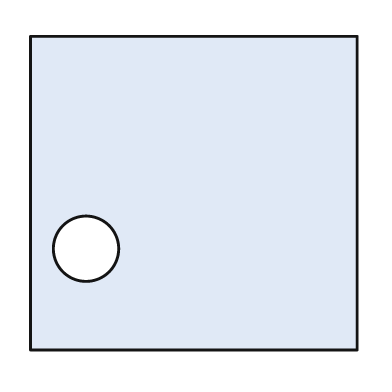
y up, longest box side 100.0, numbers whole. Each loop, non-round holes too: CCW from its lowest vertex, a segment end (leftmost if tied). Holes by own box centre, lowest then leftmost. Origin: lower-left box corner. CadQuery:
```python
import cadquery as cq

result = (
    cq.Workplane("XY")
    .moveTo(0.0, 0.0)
    .lineTo(100.0, 0.0)
    .lineTo(100.0, 96.0)
    .lineTo(0.0, 96.0)
    .close()
    .moveTo(17.0, 31.0)
    .circle(10.0)
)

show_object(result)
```